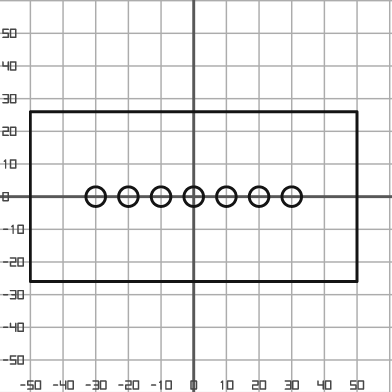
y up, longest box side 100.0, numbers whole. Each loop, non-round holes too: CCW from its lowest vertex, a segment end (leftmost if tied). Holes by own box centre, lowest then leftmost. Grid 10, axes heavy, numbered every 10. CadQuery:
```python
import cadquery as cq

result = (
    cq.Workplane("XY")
    .moveTo(-50.0, -26.0)
    .lineTo(50.0, -26.0)
    .lineTo(50.0, 26.0)
    .lineTo(-50.0, 26.0)
    .close()
    .moveTo(-30.0, 0.0)
    .circle(3.0)
    .moveTo(-20.0, 0.0)
    .circle(3.0)
    .moveTo(-10.0, 0.0)
    .circle(3.0)
    .moveTo(0.0, 0.0)
    .circle(3.0)
    .moveTo(10.0, 0.0)
    .circle(3.0)
    .moveTo(20.0, 0.0)
    .circle(3.0)
    .moveTo(30.0, 0.0)
    .circle(3.0)
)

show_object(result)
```